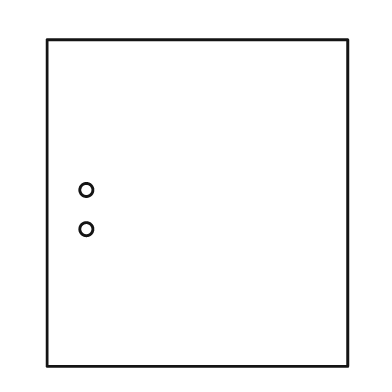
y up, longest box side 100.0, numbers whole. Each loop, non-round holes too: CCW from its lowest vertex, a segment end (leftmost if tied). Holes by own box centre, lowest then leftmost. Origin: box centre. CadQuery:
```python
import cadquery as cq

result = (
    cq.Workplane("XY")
    .moveTo(-46.0, -50.0)
    .lineTo(46.0, -50.0)
    .lineTo(46.0, 50.0)
    .lineTo(-46.0, 50.0)
    .close()
    .moveTo(-34.0, -8.0)
    .circle(2.0)
    .moveTo(-34.0, 4.0)
    .circle(2.0)
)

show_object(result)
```